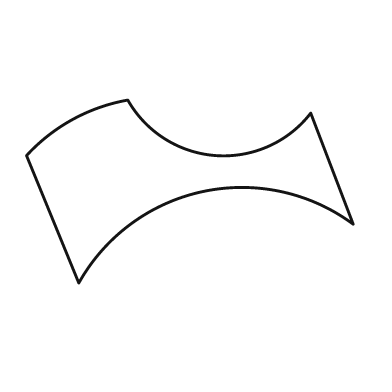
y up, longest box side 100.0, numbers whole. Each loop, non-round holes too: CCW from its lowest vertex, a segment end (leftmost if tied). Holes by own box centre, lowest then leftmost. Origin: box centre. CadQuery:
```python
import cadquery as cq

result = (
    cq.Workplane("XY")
    .moveTo(-34.0, -28.0)
    .threePointArc((4.0, 0.0), (50.0, -10.0))
    .lineTo(37.0, 24.0)
    .threePointArc((8.0, 11.0), (-19.0, 28.0))
    .threePointArc((-36.0, 22.0), (-50.0, 11.0))
    .close()
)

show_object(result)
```